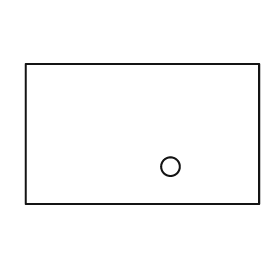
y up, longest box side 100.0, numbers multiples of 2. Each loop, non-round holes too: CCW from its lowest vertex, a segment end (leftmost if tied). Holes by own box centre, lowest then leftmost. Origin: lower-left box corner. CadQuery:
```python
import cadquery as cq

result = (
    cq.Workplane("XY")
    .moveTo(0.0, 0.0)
    .lineTo(100.0, 0.0)
    .lineTo(100.0, 60.0)
    .lineTo(0.0, 60.0)
    .close()
    .moveTo(62.0, 16.0)
    .circle(4.0)
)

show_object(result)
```